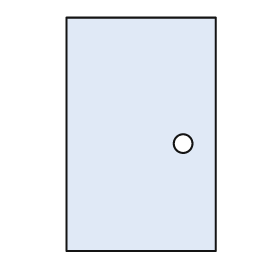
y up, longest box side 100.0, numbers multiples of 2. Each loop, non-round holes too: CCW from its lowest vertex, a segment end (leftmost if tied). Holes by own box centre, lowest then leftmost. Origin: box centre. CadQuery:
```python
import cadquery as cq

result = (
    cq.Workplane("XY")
    .moveTo(-32.0, -50.0)
    .lineTo(32.0, -50.0)
    .lineTo(32.0, 50.0)
    .lineTo(-32.0, 50.0)
    .close()
    .moveTo(18.0, -4.0)
    .circle(4.0)
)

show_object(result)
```